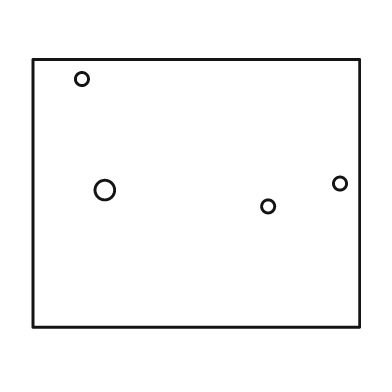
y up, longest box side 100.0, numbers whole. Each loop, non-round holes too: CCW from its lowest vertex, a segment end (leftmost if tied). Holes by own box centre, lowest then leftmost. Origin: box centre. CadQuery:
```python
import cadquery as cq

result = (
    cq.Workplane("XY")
    .moveTo(-50.0, -41.0)
    .lineTo(50.0, -41.0)
    .lineTo(50.0, 41.0)
    .lineTo(-50.0, 41.0)
    .close()
    .moveTo(22.0, -4.0)
    .circle(2.0)
    .moveTo(-28.0, 1.0)
    .circle(3.0)
    .moveTo(44.0, 3.0)
    .circle(2.0)
    .moveTo(-35.0, 35.0)
    .circle(2.0)
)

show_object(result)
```